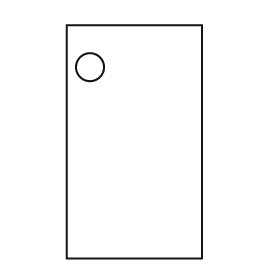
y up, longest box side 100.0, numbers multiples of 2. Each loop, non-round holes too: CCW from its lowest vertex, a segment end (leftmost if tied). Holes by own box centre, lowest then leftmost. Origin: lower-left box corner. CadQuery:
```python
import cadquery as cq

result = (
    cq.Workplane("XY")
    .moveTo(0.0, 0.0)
    .lineTo(58.0, 0.0)
    .lineTo(58.0, 100.0)
    .lineTo(0.0, 100.0)
    .close()
    .moveTo(10.0, 82.0)
    .circle(6.0)
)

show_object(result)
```